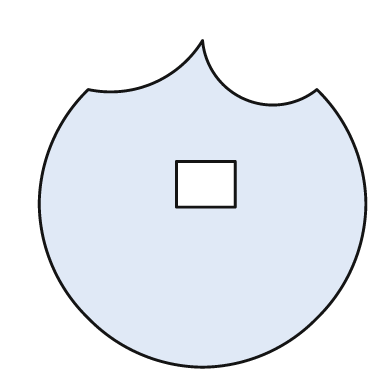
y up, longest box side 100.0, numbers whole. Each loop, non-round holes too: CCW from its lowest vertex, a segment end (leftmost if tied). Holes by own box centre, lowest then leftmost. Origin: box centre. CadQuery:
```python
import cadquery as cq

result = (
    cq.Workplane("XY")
    .moveTo(0.0, -50.0)
    .threePointArc((19.0, -46.0), (35.0, -35.0))
    .threePointArc((46.0, -19.0), (50.0, 0.0))
    .threePointArc((46.0, 19.0), (35.0, 35.0))
    .threePointArc((13.0, 32.0), (0.0, 50.0))
    .threePointArc((-15.0, 37.0), (-35.0, 35.0))
    .threePointArc((-46.0, 19.0), (-50.0, 0.0))
    .threePointArc((-46.0, -19.0), (-35.0, -35.0))
    .threePointArc((-19.0, -46.0), (0.0, -50.0))
    .close()
    .moveTo(-8.0, -1.0)
    .lineTo(10.0, -1.0)
    .lineTo(10.0, 13.0)
    .lineTo(-8.0, 13.0)
    .close()
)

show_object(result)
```